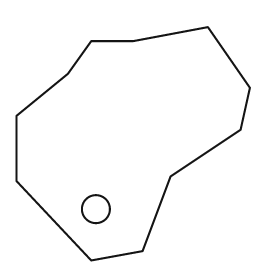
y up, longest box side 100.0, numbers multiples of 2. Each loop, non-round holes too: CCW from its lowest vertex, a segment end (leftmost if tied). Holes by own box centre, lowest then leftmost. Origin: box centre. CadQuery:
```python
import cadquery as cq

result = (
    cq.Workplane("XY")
    .moveTo(-18.0, -50.0)
    .lineTo(4.0, -46.0)
    .lineTo(16.0, -14.0)
    .lineTo(46.0, 6.0)
    .lineTo(50.0, 24.0)
    .lineTo(32.0, 50.0)
    .lineTo(0.0, 44.0)
    .lineTo(-18.0, 44.0)
    .lineTo(-28.0, 30.0)
    .lineTo(-50.0, 12.0)
    .lineTo(-50.0, -16.0)
    .close()
    .moveTo(-16.0, -28.0)
    .circle(6.0)
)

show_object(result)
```